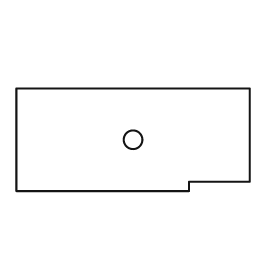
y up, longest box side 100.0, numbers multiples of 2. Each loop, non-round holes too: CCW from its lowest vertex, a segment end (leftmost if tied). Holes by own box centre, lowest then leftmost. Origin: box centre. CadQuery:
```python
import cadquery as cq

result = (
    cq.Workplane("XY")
    .moveTo(-50.0, -22.0)
    .lineTo(24.0, -22.0)
    .lineTo(24.0, -18.0)
    .lineTo(50.0, -18.0)
    .lineTo(50.0, 22.0)
    .lineTo(-50.0, 22.0)
    .close()
    .moveTo(0.0, 0.0)
    .circle(4.0)
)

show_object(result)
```